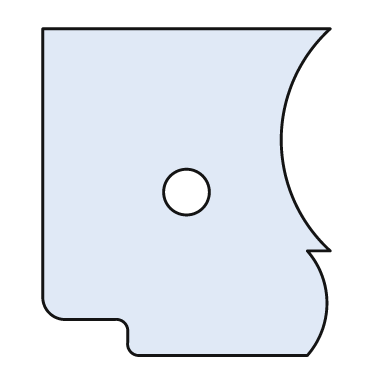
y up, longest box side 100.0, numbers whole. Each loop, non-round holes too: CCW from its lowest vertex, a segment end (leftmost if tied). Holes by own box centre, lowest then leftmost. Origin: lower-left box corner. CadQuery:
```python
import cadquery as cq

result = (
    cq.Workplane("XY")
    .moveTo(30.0, 0.0)
    .lineTo(81.0, 0.0)
    .threePointArc((87.0, 16.0), (81.0, 32.0))
    .lineTo(88.0, 32.0)
    .threePointArc((73.0, 66.0), (88.0, 100.0))
    .lineTo(0.0, 100.0)
    .lineTo(0.0, 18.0)
    .threePointArc((2.0, 13.0), (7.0, 11.0))
    .lineTo(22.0, 11.0)
    .threePointArc((25.0, 10.0), (26.0, 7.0))
    .lineTo(26.0, 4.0)
    .threePointArc((27.0, 1.0), (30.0, 0.0))
    .close()
    .moveTo(44.0, 50.0)
    .circle(7.0)
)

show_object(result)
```